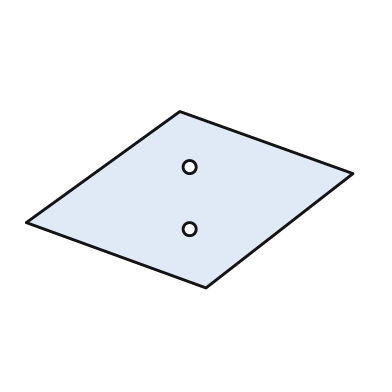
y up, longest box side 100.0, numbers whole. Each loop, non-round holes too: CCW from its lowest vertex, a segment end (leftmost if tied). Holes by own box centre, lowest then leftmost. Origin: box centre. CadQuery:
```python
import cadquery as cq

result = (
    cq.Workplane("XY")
    .moveTo(5.0, -27.0)
    .lineTo(50.0, 8.0)
    .lineTo(-3.0, 27.0)
    .lineTo(-50.0, -7.0)
    .close()
    .moveTo(0.0, -9.0)
    .circle(2.0)
    .moveTo(0.0, 10.0)
    .circle(2.0)
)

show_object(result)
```